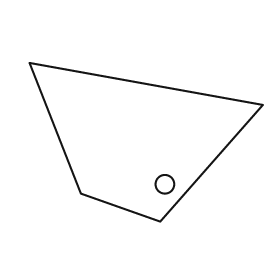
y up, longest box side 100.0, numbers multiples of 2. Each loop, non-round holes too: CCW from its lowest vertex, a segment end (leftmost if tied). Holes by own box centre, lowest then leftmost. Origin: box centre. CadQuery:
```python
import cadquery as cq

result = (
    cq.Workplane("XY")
    .moveTo(6.0, -34.0)
    .lineTo(50.0, 16.0)
    .lineTo(-50.0, 34.0)
    .lineTo(-28.0, -22.0)
    .close()
    .moveTo(8.0, -18.0)
    .circle(4.0)
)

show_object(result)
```